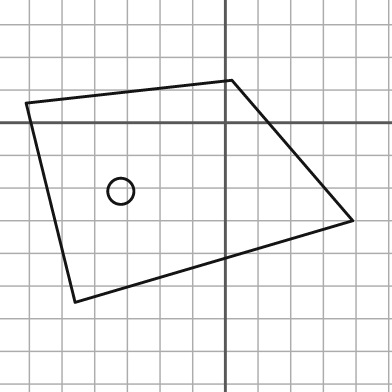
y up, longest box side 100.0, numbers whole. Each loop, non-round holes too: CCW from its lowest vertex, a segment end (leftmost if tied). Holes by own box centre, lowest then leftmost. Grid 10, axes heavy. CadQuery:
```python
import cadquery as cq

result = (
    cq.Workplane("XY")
    .moveTo(-46.0, -55.0)
    .lineTo(39.0, -30.0)
    .lineTo(2.0, 13.0)
    .lineTo(-61.0, 6.0)
    .close()
    .moveTo(-32.0, -21.0)
    .circle(4.0)
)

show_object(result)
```